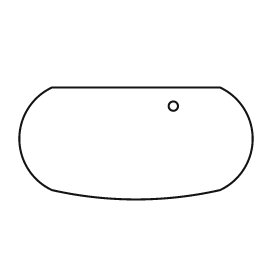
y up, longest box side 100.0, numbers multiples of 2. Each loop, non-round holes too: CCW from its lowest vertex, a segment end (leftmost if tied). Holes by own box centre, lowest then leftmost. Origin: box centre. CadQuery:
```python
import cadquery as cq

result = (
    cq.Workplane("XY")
    .moveTo(-36.0, -20.0)
    .threePointArc((0.0, -24.0), (36.0, -20.0))
    .threePointArc((50.0, 2.0), (36.0, 24.0))
    .lineTo(-36.0, 24.0)
    .threePointArc((-50.0, 2.0), (-36.0, -20.0))
    .close()
    .moveTo(16.0, 16.0)
    .circle(2.0)
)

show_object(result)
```